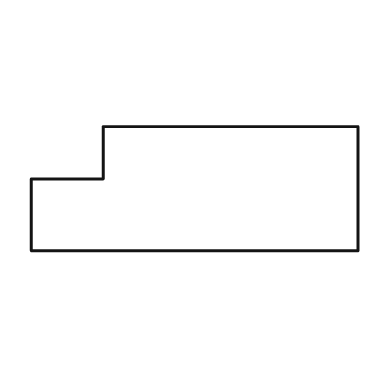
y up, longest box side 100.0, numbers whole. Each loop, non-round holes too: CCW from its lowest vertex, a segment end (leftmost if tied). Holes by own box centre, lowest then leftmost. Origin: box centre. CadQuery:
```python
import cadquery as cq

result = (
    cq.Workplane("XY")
    .moveTo(-50.0, -19.0)
    .lineTo(50.0, -19.0)
    .lineTo(50.0, 19.0)
    .lineTo(-28.0, 19.0)
    .lineTo(-28.0, 3.0)
    .lineTo(-50.0, 3.0)
    .close()
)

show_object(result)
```